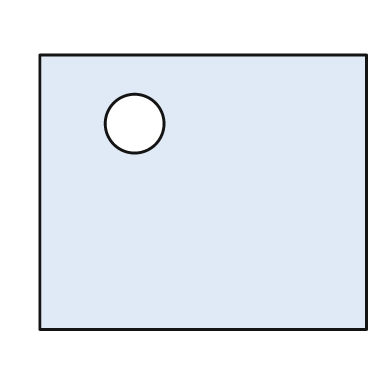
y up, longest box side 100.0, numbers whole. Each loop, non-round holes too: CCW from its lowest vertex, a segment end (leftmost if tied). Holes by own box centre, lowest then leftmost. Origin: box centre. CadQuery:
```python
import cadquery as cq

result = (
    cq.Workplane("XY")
    .moveTo(-50.0, -42.0)
    .lineTo(50.0, -42.0)
    .lineTo(50.0, 42.0)
    .lineTo(-50.0, 42.0)
    .close()
    .moveTo(-21.0, 21.0)
    .circle(9.0)
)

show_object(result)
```